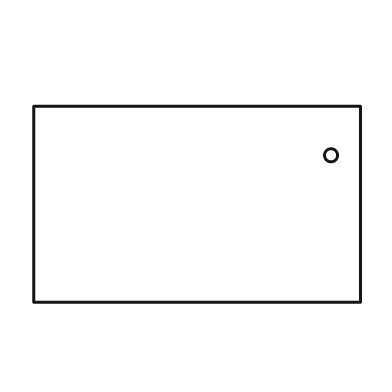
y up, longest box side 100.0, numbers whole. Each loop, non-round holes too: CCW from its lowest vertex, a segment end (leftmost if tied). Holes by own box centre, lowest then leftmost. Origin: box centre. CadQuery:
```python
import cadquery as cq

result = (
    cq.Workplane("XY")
    .moveTo(-50.0, -30.0)
    .lineTo(50.0, -30.0)
    .lineTo(50.0, 30.0)
    .lineTo(-50.0, 30.0)
    .close()
    .moveTo(41.0, 15.0)
    .circle(2.0)
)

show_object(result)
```